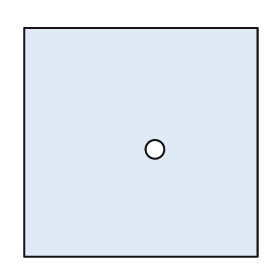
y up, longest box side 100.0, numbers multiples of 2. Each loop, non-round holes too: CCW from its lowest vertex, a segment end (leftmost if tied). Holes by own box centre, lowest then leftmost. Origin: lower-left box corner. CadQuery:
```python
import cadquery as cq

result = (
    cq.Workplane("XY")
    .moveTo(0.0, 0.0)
    .lineTo(100.0, 0.0)
    .lineTo(100.0, 98.0)
    .lineTo(0.0, 98.0)
    .close()
    .moveTo(56.0, 46.0)
    .circle(4.0)
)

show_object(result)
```